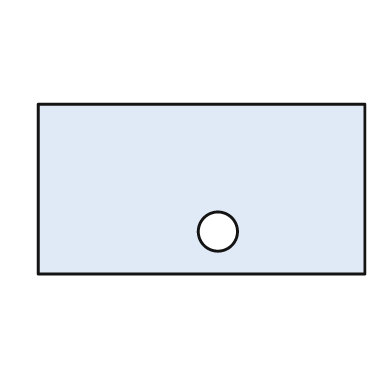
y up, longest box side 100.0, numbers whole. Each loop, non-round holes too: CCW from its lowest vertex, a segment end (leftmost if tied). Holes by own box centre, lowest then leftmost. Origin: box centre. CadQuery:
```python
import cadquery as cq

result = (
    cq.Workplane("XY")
    .moveTo(-50.0, -26.0)
    .lineTo(50.0, -26.0)
    .lineTo(50.0, 26.0)
    .lineTo(-50.0, 26.0)
    .close()
    .moveTo(5.0, -13.0)
    .circle(6.0)
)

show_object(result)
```